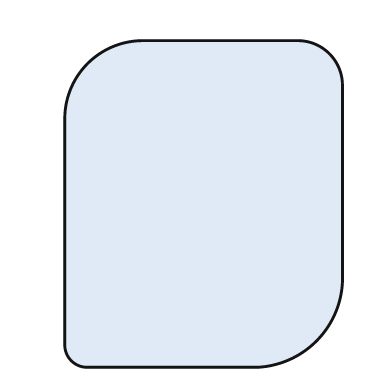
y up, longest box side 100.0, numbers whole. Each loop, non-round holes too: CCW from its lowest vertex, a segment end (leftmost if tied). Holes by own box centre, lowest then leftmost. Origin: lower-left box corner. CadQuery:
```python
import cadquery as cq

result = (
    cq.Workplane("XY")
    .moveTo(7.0, 0.0)
    .lineTo(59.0, 0.0)
    .threePointArc((77.0, 8.0), (85.0, 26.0))
    .lineTo(85.0, 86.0)
    .threePointArc((81.0, 96.0), (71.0, 100.0))
    .lineTo(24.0, 100.0)
    .threePointArc((7.0, 93.0), (0.0, 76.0))
    .lineTo(0.0, 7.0)
    .threePointArc((2.0, 2.0), (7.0, 0.0))
    .close()
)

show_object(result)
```